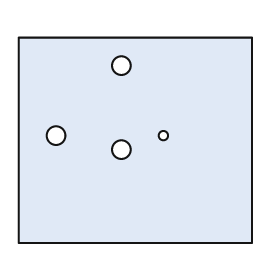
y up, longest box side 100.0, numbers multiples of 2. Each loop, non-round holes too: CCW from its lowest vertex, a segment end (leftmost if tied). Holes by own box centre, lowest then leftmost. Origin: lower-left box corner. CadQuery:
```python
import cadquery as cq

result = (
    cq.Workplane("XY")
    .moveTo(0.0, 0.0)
    .lineTo(100.0, 0.0)
    .lineTo(100.0, 88.0)
    .lineTo(0.0, 88.0)
    .close()
    .moveTo(44.0, 40.0)
    .circle(4.0)
    .moveTo(16.0, 46.0)
    .circle(4.0)
    .moveTo(62.0, 46.0)
    .circle(2.0)
    .moveTo(44.0, 76.0)
    .circle(4.0)
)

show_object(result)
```